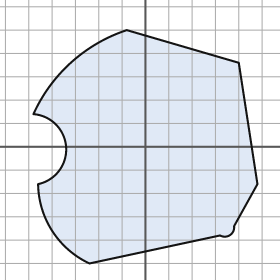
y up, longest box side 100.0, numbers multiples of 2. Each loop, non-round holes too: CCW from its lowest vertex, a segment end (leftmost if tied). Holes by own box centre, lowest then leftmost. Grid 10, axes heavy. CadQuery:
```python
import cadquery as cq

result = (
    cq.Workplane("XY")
    .moveTo(-24.0, -50.0)
    .lineTo(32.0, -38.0)
    .threePointArc((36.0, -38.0), (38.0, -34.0))
    .lineTo(48.0, -16.0)
    .lineTo(40.0, 36.0)
    .lineTo(-8.0, 50.0)
    .threePointArc((-32.0, 36.0), (-48.0, 14.0))
    .threePointArc((-34.0, 0.0), (-46.0, -16.0))
    .threePointArc((-40.0, -36.0), (-24.0, -50.0))
    .close()
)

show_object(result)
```